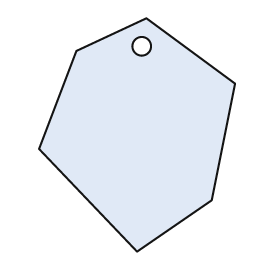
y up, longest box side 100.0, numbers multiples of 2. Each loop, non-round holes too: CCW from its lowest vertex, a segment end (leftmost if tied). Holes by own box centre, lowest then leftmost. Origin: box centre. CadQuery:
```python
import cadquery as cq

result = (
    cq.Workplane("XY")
    .moveTo(0.0, -50.0)
    .lineTo(32.0, -28.0)
    .lineTo(42.0, 22.0)
    .lineTo(4.0, 50.0)
    .lineTo(-26.0, 36.0)
    .lineTo(-42.0, -6.0)
    .close()
    .moveTo(2.0, 38.0)
    .circle(4.0)
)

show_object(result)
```